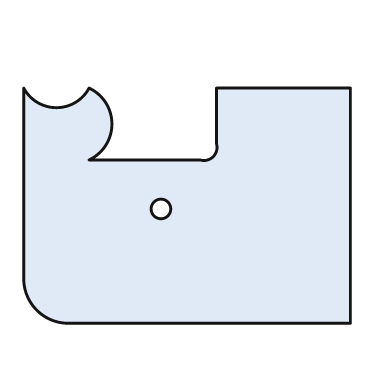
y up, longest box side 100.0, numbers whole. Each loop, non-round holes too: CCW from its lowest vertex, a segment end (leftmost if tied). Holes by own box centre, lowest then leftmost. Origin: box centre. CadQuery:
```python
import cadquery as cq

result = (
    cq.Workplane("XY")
    .moveTo(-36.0, -36.0)
    .lineTo(50.0, -36.0)
    .lineTo(50.0, 36.0)
    .lineTo(9.0, 36.0)
    .lineTo(9.0, 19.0)
    .threePointArc((8.0, 15.0), (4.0, 14.0))
    .lineTo(-30.0, 14.0)
    .threePointArc((-23.0, 25.0), (-30.0, 36.0))
    .threePointArc((-40.0, 30.0), (-50.0, 36.0))
    .lineTo(-50.0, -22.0)
    .threePointArc((-46.0, -32.0), (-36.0, -36.0))
    .close()
    .moveTo(-8.0, -1.0)
    .circle(3.0)
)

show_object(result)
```